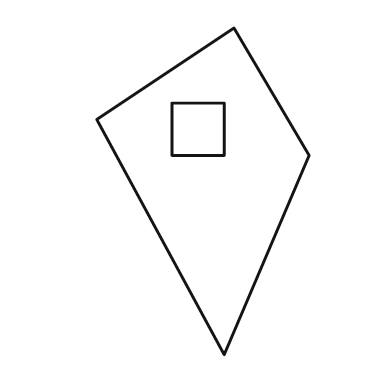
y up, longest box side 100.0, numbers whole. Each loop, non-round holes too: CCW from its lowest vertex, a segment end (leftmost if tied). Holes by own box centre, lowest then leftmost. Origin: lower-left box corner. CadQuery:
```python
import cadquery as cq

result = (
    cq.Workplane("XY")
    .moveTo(39.0, 0.0)
    .lineTo(65.0, 61.0)
    .lineTo(42.0, 100.0)
    .lineTo(0.0, 72.0)
    .close()
    .moveTo(23.0, 61.0)
    .lineTo(39.0, 61.0)
    .lineTo(39.0, 77.0)
    .lineTo(23.0, 77.0)
    .close()
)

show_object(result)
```